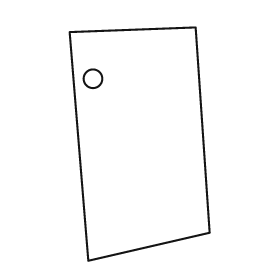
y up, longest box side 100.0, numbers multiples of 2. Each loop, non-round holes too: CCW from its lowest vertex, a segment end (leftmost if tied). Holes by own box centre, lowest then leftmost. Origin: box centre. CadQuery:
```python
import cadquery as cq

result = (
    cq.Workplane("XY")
    .moveTo(-22.0, -50.0)
    .lineTo(30.0, -38.0)
    .lineTo(24.0, 50.0)
    .lineTo(-30.0, 48.0)
    .close()
    .moveTo(-20.0, 28.0)
    .circle(4.0)
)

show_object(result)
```